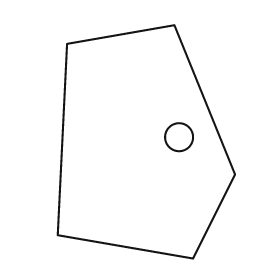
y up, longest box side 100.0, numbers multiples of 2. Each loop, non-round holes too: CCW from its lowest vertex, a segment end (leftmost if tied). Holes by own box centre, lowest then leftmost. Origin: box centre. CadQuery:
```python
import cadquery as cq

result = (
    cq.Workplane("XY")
    .moveTo(20.0, -50.0)
    .lineTo(38.0, -14.0)
    .lineTo(12.0, 50.0)
    .lineTo(-34.0, 42.0)
    .lineTo(-38.0, -40.0)
    .close()
    .moveTo(14.0, 2.0)
    .circle(6.0)
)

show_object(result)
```